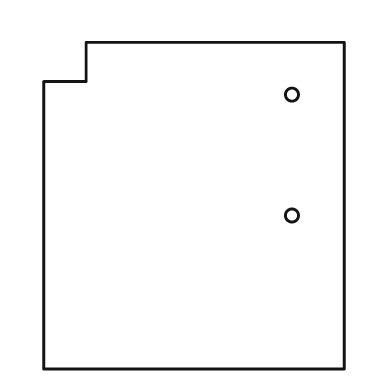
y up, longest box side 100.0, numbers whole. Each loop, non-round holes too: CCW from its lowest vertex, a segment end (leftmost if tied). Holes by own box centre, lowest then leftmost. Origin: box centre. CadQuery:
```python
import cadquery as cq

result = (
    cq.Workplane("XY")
    .moveTo(-46.0, -50.0)
    .lineTo(46.0, -50.0)
    .lineTo(46.0, 50.0)
    .lineTo(-33.0, 50.0)
    .lineTo(-33.0, 38.0)
    .lineTo(-46.0, 38.0)
    .close()
    .moveTo(30.0, -3.0)
    .circle(2.0)
    .moveTo(30.0, 34.0)
    .circle(2.0)
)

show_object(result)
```